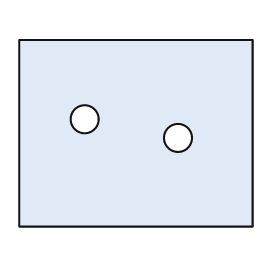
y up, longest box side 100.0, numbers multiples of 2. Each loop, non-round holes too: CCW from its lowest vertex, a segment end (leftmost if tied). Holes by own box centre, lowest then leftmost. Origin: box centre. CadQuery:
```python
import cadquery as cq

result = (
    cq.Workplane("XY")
    .moveTo(-50.0, -40.0)
    .lineTo(50.0, -40.0)
    .lineTo(50.0, 40.0)
    .lineTo(-50.0, 40.0)
    .close()
    .moveTo(18.0, -2.0)
    .circle(6.0)
    .moveTo(-22.0, 6.0)
    .circle(6.0)
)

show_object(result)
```